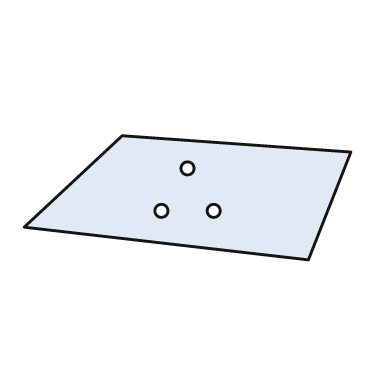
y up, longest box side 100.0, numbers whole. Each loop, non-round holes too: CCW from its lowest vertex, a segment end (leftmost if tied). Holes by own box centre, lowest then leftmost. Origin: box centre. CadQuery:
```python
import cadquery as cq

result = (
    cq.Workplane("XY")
    .moveTo(37.0, -19.0)
    .lineTo(50.0, 14.0)
    .lineTo(-20.0, 19.0)
    .lineTo(-50.0, -9.0)
    .close()
    .moveTo(-8.0, -4.0)
    .circle(2.0)
    .moveTo(8.0, -4.0)
    .circle(2.0)
    .moveTo(0.0, 9.0)
    .circle(2.0)
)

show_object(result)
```